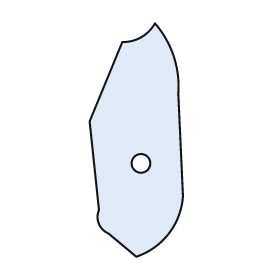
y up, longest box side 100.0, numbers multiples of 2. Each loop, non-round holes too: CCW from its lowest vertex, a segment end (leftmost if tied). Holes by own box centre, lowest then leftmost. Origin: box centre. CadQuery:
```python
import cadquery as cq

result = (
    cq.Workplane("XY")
    .moveTo(0.0, -50.0)
    .threePointArc((14.0, -40.0), (20.0, -24.0))
    .lineTo(18.0, 20.0)
    .threePointArc((16.0, 36.0), (8.0, 50.0))
    .threePointArc((2.0, 44.0), (-6.0, 42.0))
    .lineTo(-20.0, 8.0)
    .lineTo(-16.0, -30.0)
    .threePointArc((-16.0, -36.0), (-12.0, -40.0))
    .close()
    .moveTo(2.0, -10.0)
    .circle(4.0)
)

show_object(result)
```